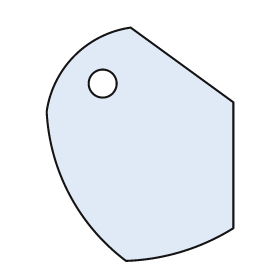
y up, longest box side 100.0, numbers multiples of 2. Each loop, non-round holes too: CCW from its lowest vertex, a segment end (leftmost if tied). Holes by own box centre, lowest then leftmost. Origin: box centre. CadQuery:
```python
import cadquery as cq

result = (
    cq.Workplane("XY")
    .moveTo(-6.0, -50.0)
    .threePointArc((18.0, -46.0), (40.0, -36.0))
    .lineTo(40.0, 18.0)
    .lineTo(-4.0, 50.0)
    .threePointArc((-28.0, 38.0), (-40.0, 14.0))
    .threePointArc((-30.0, -22.0), (-6.0, -50.0))
    .close()
    .moveTo(-16.0, 26.0)
    .circle(6.0)
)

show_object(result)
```